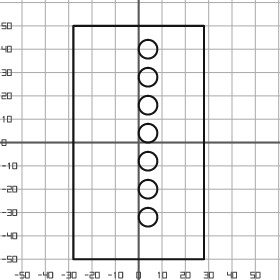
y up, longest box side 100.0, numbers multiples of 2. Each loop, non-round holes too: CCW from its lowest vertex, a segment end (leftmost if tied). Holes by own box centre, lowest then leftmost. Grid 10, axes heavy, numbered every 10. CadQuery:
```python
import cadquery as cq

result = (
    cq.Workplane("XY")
    .moveTo(-28.0, -50.0)
    .lineTo(28.0, -50.0)
    .lineTo(28.0, 50.0)
    .lineTo(-28.0, 50.0)
    .close()
    .moveTo(4.0, -32.0)
    .circle(4.0)
    .moveTo(4.0, -20.0)
    .circle(4.0)
    .moveTo(4.0, -8.0)
    .circle(4.0)
    .moveTo(4.0, 4.0)
    .circle(4.0)
    .moveTo(4.0, 16.0)
    .circle(4.0)
    .moveTo(4.0, 28.0)
    .circle(4.0)
    .moveTo(4.0, 40.0)
    .circle(4.0)
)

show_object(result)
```